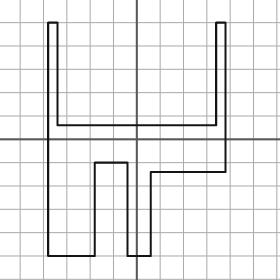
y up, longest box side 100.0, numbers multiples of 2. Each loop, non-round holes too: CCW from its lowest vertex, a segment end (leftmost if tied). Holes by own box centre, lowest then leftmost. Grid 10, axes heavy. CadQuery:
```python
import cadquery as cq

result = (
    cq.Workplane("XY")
    .moveTo(-38.0, -50.0)
    .lineTo(-18.0, -50.0)
    .lineTo(-18.0, -10.0)
    .lineTo(-4.0, -10.0)
    .lineTo(-4.0, -50.0)
    .lineTo(6.0, -50.0)
    .lineTo(6.0, -14.0)
    .lineTo(38.0, -14.0)
    .lineTo(38.0, 50.0)
    .lineTo(34.0, 50.0)
    .lineTo(34.0, 6.0)
    .lineTo(-34.0, 6.0)
    .lineTo(-34.0, 50.0)
    .lineTo(-38.0, 50.0)
    .close()
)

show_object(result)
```